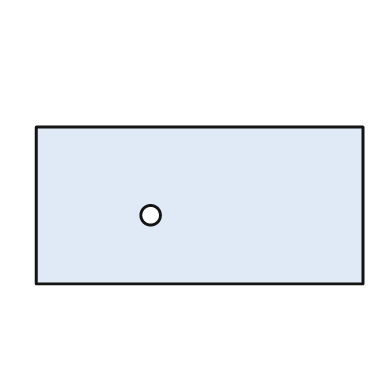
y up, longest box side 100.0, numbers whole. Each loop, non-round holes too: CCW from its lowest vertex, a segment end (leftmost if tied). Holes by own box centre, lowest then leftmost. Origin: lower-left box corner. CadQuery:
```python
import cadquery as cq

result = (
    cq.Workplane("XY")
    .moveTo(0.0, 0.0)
    .lineTo(100.0, 0.0)
    .lineTo(100.0, 48.0)
    .lineTo(0.0, 48.0)
    .close()
    .moveTo(35.0, 21.0)
    .circle(3.0)
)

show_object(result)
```